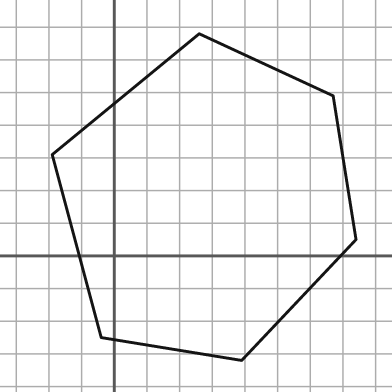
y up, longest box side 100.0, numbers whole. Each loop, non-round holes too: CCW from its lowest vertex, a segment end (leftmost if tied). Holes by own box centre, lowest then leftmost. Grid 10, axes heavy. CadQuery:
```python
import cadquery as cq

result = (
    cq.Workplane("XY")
    .moveTo(39.0, -32.0)
    .lineTo(74.0, 5.0)
    .lineTo(67.0, 49.0)
    .lineTo(26.0, 68.0)
    .lineTo(-19.0, 31.0)
    .lineTo(-4.0, -25.0)
    .close()
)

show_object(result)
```